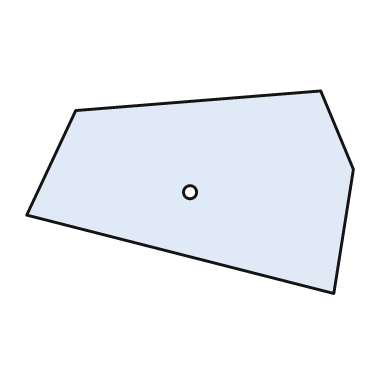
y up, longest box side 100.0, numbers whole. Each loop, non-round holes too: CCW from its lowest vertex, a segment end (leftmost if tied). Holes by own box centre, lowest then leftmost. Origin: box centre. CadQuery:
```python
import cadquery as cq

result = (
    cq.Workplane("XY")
    .moveTo(44.0, -31.0)
    .lineTo(50.0, 7.0)
    .lineTo(40.0, 31.0)
    .lineTo(-35.0, 25.0)
    .lineTo(-50.0, -7.0)
    .close()
    .moveTo(0.0, 0.0)
    .circle(2.0)
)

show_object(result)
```